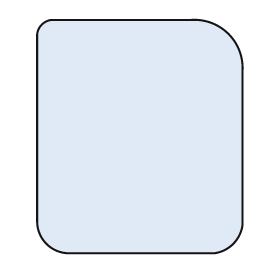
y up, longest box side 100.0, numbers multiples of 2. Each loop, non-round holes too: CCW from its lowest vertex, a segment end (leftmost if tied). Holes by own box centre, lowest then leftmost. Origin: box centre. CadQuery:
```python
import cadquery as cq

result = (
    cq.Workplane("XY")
    .moveTo(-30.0, -50.0)
    .lineTo(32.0, -50.0)
    .threePointArc((40.0, -46.0), (44.0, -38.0))
    .lineTo(44.0, 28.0)
    .threePointArc((38.0, 44.0), (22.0, 50.0))
    .lineTo(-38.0, 50.0)
    .threePointArc((-42.0, 48.0), (-44.0, 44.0))
    .lineTo(-44.0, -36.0)
    .threePointArc((-40.0, -46.0), (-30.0, -50.0))
    .close()
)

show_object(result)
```